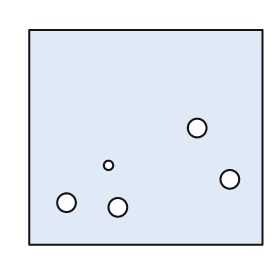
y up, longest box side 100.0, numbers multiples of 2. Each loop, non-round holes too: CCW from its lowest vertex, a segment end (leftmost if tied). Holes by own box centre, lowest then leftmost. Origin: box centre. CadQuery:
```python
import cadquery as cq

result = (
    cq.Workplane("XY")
    .moveTo(-50.0, -46.0)
    .lineTo(50.0, -46.0)
    .lineTo(50.0, 46.0)
    .lineTo(-50.0, 46.0)
    .close()
    .moveTo(-12.0, -30.0)
    .circle(4.0)
    .moveTo(-34.0, -28.0)
    .circle(4.0)
    .moveTo(36.0, -18.0)
    .circle(4.0)
    .moveTo(-16.0, -12.0)
    .circle(2.0)
    .moveTo(22.0, 4.0)
    .circle(4.0)
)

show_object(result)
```